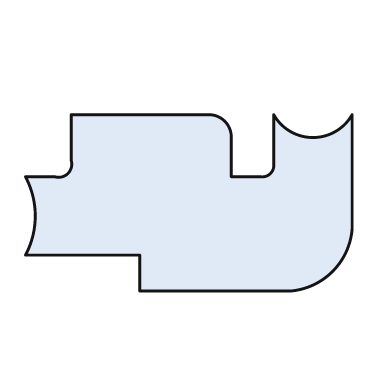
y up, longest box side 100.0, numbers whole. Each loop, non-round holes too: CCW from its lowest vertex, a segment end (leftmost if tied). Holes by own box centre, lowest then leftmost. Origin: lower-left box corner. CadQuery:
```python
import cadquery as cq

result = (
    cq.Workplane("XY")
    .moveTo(35.0, 0.0)
    .lineTo(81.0, 0.0)
    .threePointArc((94.0, 6.0), (100.0, 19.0))
    .lineTo(100.0, 54.0)
    .threePointArc((88.0, 47.0), (76.0, 54.0))
    .lineTo(76.0, 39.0)
    .threePointArc((75.0, 36.0), (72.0, 35.0))
    .lineTo(63.0, 35.0)
    .lineTo(63.0, 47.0)
    .threePointArc((61.0, 52.0), (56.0, 54.0))
    .lineTo(14.0, 54.0)
    .lineTo(14.0, 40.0)
    .threePointArc((13.0, 36.0), (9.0, 35.0))
    .lineTo(0.0, 35.0)
    .threePointArc((3.0, 23.0), (0.0, 11.0))
    .lineTo(35.0, 11.0)
    .close()
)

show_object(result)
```